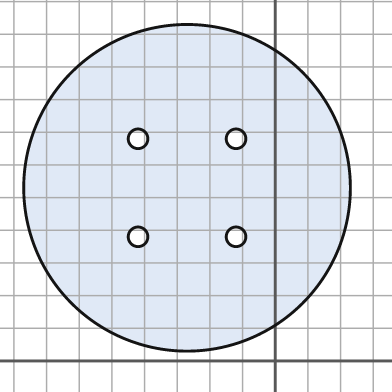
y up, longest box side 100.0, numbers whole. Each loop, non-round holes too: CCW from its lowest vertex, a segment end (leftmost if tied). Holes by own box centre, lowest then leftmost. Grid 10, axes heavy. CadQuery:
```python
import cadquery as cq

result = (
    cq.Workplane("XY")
    .moveTo(-27.0, 53.0)
    .circle(50.0)
    .moveTo(-42.0, 38.0)
    .circle(3.0)
    .moveTo(-12.0, 38.0)
    .circle(3.0)
    .moveTo(-42.0, 68.0)
    .circle(3.0)
    .moveTo(-12.0, 68.0)
    .circle(3.0)
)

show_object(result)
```